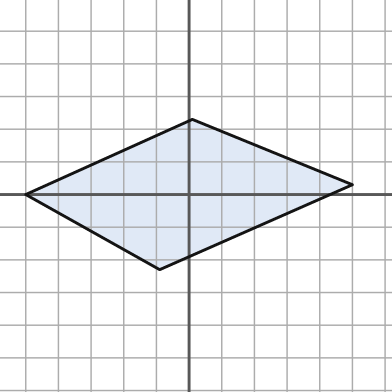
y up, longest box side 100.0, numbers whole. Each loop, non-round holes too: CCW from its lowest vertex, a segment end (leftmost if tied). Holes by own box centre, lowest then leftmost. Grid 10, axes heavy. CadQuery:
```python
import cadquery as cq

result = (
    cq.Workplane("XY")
    .moveTo(-9.0, -23.0)
    .lineTo(50.0, 3.0)
    .lineTo(1.0, 23.0)
    .lineTo(-50.0, 0.0)
    .close()
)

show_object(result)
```